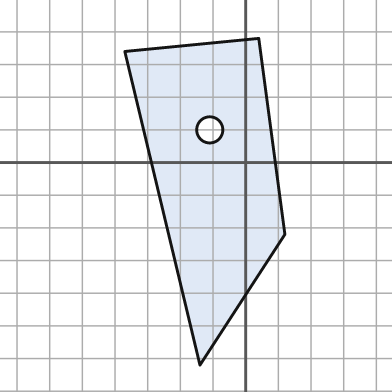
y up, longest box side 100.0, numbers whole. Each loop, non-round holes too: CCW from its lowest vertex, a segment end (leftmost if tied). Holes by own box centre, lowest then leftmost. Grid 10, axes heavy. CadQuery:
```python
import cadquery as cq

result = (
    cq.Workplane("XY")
    .moveTo(-14.0, -62.0)
    .lineTo(12.0, -22.0)
    .lineTo(4.0, 38.0)
    .lineTo(-37.0, 34.0)
    .close()
    .moveTo(-11.0, 10.0)
    .circle(4.0)
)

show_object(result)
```